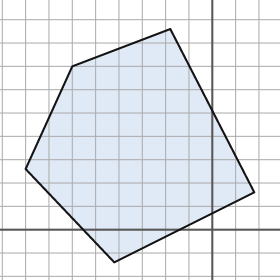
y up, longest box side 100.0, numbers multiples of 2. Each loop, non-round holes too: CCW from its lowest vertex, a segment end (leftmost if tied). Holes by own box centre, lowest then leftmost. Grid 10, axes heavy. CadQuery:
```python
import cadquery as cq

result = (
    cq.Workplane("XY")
    .moveTo(-42.0, -14.0)
    .lineTo(18.0, 16.0)
    .lineTo(-18.0, 86.0)
    .lineTo(-60.0, 70.0)
    .lineTo(-80.0, 26.0)
    .close()
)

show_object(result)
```